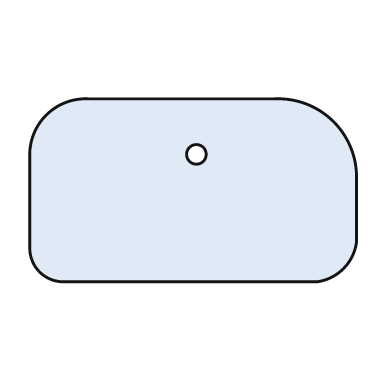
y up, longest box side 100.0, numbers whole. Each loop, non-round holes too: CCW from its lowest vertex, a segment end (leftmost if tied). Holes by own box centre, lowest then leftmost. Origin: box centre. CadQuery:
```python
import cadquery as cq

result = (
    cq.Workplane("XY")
    .moveTo(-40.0, -28.0)
    .lineTo(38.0, -28.0)
    .threePointArc((46.0, -24.0), (50.0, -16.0))
    .lineTo(50.0, 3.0)
    .threePointArc((43.0, 21.0), (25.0, 28.0))
    .lineTo(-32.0, 28.0)
    .threePointArc((-45.0, 23.0), (-50.0, 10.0))
    .lineTo(-50.0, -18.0)
    .threePointArc((-47.0, -25.0), (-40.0, -28.0))
    .close()
    .moveTo(1.0, 11.0)
    .circle(3.0)
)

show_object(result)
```